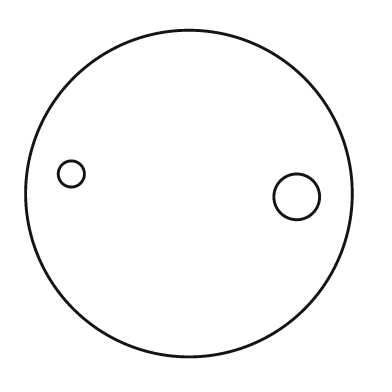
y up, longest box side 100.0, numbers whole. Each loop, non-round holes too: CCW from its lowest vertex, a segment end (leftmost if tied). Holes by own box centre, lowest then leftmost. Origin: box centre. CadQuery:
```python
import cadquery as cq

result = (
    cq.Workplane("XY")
    .moveTo(0.0, 0.0)
    .circle(50.0)
    .moveTo(33.0, -1.0)
    .circle(7.0)
    .moveTo(-36.0, 6.0)
    .circle(4.0)
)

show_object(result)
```